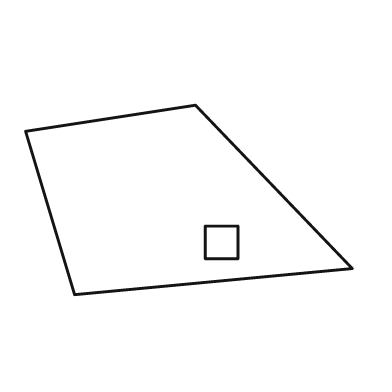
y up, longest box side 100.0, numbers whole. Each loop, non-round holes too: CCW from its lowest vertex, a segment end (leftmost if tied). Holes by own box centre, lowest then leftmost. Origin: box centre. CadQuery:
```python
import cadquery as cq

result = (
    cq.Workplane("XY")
    .moveTo(-35.0, -29.0)
    .lineTo(50.0, -21.0)
    .lineTo(2.0, 29.0)
    .lineTo(-50.0, 21.0)
    .close()
    .moveTo(5.0, -18.0)
    .lineTo(15.0, -18.0)
    .lineTo(15.0, -8.0)
    .lineTo(5.0, -8.0)
    .close()
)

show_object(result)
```